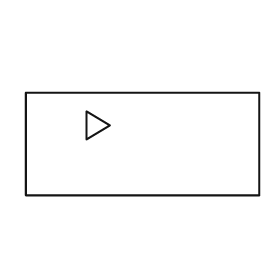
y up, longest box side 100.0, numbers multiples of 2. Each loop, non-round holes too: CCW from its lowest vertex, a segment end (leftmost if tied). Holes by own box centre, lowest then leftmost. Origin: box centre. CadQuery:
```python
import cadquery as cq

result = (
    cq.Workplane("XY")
    .moveTo(-50.0, -22.0)
    .lineTo(50.0, -22.0)
    .lineTo(50.0, 22.0)
    .lineTo(-50.0, 22.0)
    .close()
    .moveTo(-24.0, 2.0)
    .lineTo(-14.0, 8.0)
    .lineTo(-24.0, 14.0)
    .close()
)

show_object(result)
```